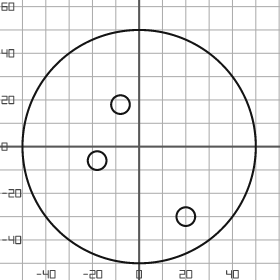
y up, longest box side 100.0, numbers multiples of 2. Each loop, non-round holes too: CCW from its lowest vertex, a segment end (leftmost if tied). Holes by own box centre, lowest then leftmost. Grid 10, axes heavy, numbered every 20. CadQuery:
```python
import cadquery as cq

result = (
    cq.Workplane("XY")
    .moveTo(0.0, 0.0)
    .circle(50.0)
    .moveTo(20.0, -30.0)
    .circle(4.0)
    .moveTo(-18.0, -6.0)
    .circle(4.0)
    .moveTo(-8.0, 18.0)
    .circle(4.0)
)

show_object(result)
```